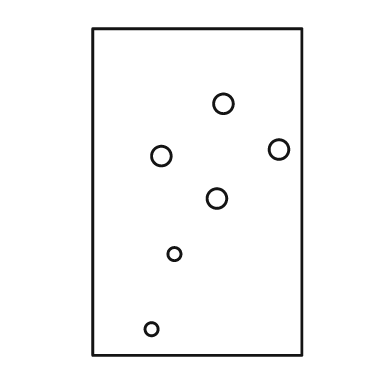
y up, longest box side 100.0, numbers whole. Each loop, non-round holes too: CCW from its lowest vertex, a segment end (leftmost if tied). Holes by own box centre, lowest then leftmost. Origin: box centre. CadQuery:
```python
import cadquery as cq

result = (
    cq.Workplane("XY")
    .moveTo(-32.0, -50.0)
    .lineTo(32.0, -50.0)
    .lineTo(32.0, 50.0)
    .lineTo(-32.0, 50.0)
    .close()
    .moveTo(-14.0, -42.0)
    .circle(2.0)
    .moveTo(-7.0, -19.0)
    .circle(2.0)
    .moveTo(6.0, -2.0)
    .circle(3.0)
    .moveTo(-11.0, 11.0)
    .circle(3.0)
    .moveTo(25.0, 13.0)
    .circle(3.0)
    .moveTo(8.0, 27.0)
    .circle(3.0)
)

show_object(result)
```